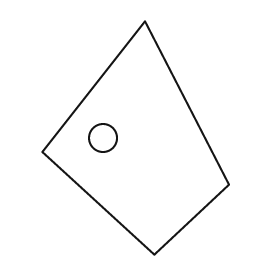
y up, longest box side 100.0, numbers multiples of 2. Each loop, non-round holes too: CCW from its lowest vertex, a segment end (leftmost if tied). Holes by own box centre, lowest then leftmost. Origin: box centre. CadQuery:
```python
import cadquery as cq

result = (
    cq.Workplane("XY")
    .moveTo(8.0, -50.0)
    .lineTo(40.0, -20.0)
    .lineTo(4.0, 50.0)
    .lineTo(-40.0, -6.0)
    .close()
    .moveTo(-14.0, 0.0)
    .circle(6.0)
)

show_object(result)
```